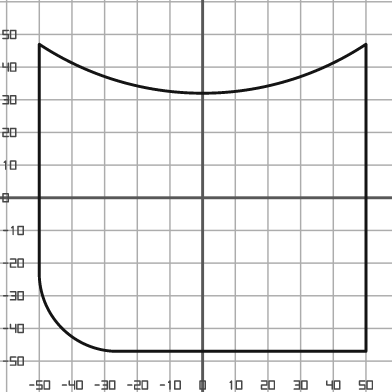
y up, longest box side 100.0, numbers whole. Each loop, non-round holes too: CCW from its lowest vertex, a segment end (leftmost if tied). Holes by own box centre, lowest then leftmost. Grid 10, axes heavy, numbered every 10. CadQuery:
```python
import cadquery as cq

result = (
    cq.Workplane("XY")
    .moveTo(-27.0, -47.0)
    .lineTo(50.0, -47.0)
    .lineTo(50.0, 47.0)
    .threePointArc((0.0, 32.0), (-50.0, 47.0))
    .lineTo(-50.0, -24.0)
    .threePointArc((-43.0, -40.0), (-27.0, -47.0))
    .close()
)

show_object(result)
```